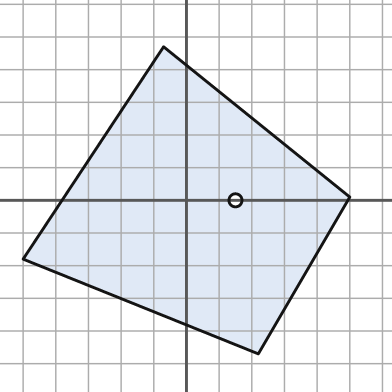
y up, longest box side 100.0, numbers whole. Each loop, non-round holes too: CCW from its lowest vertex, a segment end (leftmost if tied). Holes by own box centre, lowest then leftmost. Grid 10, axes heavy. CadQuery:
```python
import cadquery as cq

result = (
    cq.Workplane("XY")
    .moveTo(22.0, -47.0)
    .lineTo(50.0, 1.0)
    .lineTo(-7.0, 47.0)
    .lineTo(-50.0, -18.0)
    .close()
    .moveTo(15.0, 0.0)
    .circle(2.0)
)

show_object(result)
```